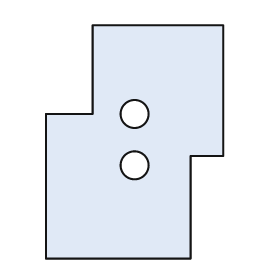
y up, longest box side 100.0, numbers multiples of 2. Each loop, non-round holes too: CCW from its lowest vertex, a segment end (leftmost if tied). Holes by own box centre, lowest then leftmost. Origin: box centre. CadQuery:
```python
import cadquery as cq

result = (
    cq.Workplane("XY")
    .moveTo(-38.0, -50.0)
    .lineTo(24.0, -50.0)
    .lineTo(24.0, -6.0)
    .lineTo(38.0, -6.0)
    .lineTo(38.0, 50.0)
    .lineTo(-18.0, 50.0)
    .lineTo(-18.0, 12.0)
    .lineTo(-38.0, 12.0)
    .close()
    .moveTo(0.0, -10.0)
    .circle(6.0)
    .moveTo(0.0, 12.0)
    .circle(6.0)
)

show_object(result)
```